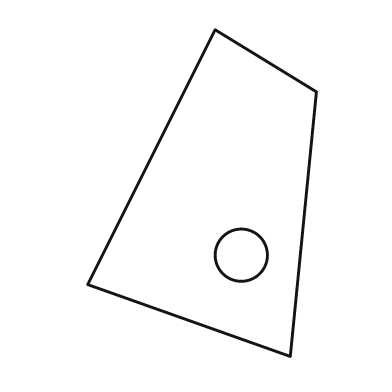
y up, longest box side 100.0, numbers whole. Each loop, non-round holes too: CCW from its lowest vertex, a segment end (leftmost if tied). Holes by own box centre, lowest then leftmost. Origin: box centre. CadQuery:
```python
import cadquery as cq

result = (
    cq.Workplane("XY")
    .moveTo(27.0, -50.0)
    .lineTo(35.0, 31.0)
    .lineTo(4.0, 50.0)
    .lineTo(-35.0, -28.0)
    .close()
    .moveTo(12.0, -19.0)
    .circle(8.0)
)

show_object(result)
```